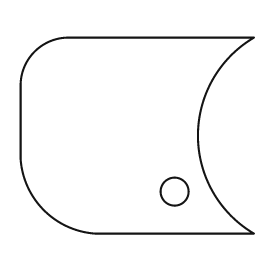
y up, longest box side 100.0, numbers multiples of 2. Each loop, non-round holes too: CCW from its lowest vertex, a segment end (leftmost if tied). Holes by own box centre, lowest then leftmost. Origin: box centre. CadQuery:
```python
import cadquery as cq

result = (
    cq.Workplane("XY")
    .moveTo(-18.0, -42.0)
    .lineTo(50.0, -42.0)
    .threePointArc((26.0, 0.0), (50.0, 42.0))
    .lineTo(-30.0, 42.0)
    .threePointArc((-44.0, 36.0), (-50.0, 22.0))
    .lineTo(-50.0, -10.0)
    .threePointArc((-40.0, -32.0), (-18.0, -42.0))
    .close()
    .moveTo(16.0, -24.0)
    .circle(6.0)
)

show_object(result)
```